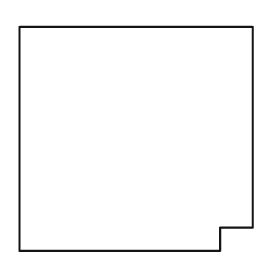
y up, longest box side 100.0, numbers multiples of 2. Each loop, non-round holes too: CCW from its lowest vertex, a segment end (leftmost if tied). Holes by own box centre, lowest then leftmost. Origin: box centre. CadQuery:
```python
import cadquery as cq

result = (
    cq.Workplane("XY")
    .moveTo(-50.0, -48.0)
    .lineTo(36.0, -48.0)
    .lineTo(36.0, -38.0)
    .lineTo(50.0, -38.0)
    .lineTo(50.0, 48.0)
    .lineTo(-50.0, 48.0)
    .close()
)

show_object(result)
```